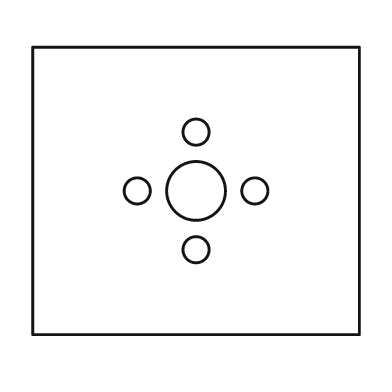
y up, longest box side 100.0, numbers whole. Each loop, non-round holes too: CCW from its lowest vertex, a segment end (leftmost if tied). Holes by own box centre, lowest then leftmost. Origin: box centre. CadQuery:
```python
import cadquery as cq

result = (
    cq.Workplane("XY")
    .moveTo(-50.0, -44.0)
    .lineTo(50.0, -44.0)
    .lineTo(50.0, 44.0)
    .lineTo(-50.0, 44.0)
    .close()
    .moveTo(0.0, -18.0)
    .circle(4.0)
    .moveTo(-18.0, 0.0)
    .circle(4.0)
    .moveTo(0.0, 0.0)
    .circle(9.0)
    .moveTo(18.0, 0.0)
    .circle(4.0)
    .moveTo(0.0, 18.0)
    .circle(4.0)
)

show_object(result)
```